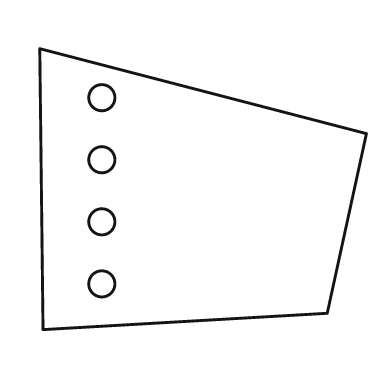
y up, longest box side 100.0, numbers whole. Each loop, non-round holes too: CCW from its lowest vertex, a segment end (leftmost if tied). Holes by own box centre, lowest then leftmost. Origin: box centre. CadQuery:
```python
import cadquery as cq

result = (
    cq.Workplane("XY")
    .moveTo(-49.0, -43.0)
    .lineTo(38.0, -38.0)
    .lineTo(50.0, 17.0)
    .lineTo(-50.0, 43.0)
    .close()
    .moveTo(-31.0, -29.0)
    .circle(4.0)
    .moveTo(-31.0, -10.0)
    .circle(4.0)
    .moveTo(-31.0, 9.0)
    .circle(4.0)
    .moveTo(-31.0, 28.0)
    .circle(4.0)
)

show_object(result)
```